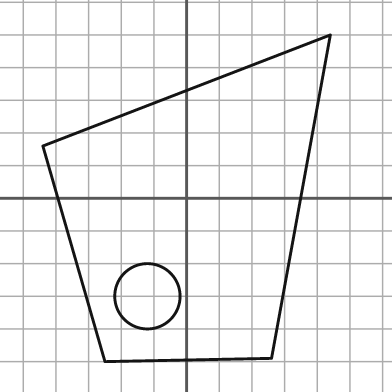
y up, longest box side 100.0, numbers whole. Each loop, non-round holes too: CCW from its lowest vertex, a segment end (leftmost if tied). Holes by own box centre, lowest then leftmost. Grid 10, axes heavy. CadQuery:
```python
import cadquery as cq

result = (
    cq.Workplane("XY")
    .moveTo(-25.0, -50.0)
    .lineTo(26.0, -49.0)
    .lineTo(44.0, 50.0)
    .lineTo(-44.0, 16.0)
    .close()
    .moveTo(-12.0, -30.0)
    .circle(10.0)
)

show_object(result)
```